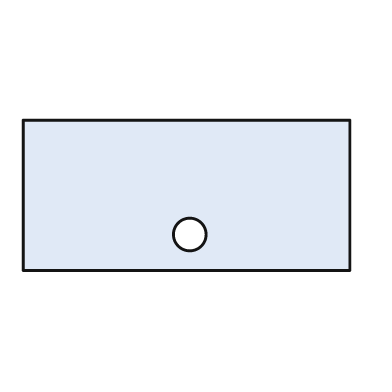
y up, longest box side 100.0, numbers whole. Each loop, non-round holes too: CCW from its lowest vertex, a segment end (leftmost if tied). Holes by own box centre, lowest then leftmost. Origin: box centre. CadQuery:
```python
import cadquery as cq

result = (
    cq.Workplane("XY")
    .moveTo(-50.0, -23.0)
    .lineTo(50.0, -23.0)
    .lineTo(50.0, 23.0)
    .lineTo(-50.0, 23.0)
    .close()
    .moveTo(1.0, -12.0)
    .circle(5.0)
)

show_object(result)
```